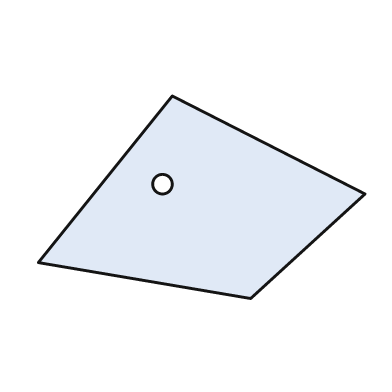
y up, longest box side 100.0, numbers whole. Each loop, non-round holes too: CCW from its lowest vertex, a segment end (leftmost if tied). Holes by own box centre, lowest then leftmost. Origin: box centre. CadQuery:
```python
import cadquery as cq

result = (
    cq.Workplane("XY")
    .moveTo(15.0, -31.0)
    .lineTo(50.0, 1.0)
    .lineTo(-9.0, 31.0)
    .lineTo(-50.0, -20.0)
    .close()
    .moveTo(-12.0, 4.0)
    .circle(3.0)
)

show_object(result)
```